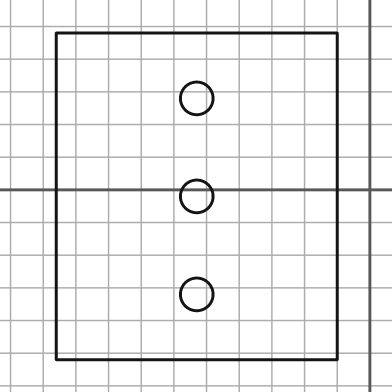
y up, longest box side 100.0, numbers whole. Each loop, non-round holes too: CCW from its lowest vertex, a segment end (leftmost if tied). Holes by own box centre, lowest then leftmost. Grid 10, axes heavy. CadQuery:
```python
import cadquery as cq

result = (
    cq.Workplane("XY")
    .moveTo(-96.0, -52.0)
    .lineTo(-10.0, -52.0)
    .lineTo(-10.0, 48.0)
    .lineTo(-96.0, 48.0)
    .close()
    .moveTo(-53.0, -32.0)
    .circle(5.0)
    .moveTo(-53.0, -2.0)
    .circle(5.0)
    .moveTo(-53.0, 28.0)
    .circle(5.0)
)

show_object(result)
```